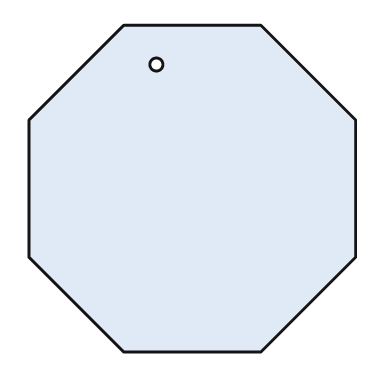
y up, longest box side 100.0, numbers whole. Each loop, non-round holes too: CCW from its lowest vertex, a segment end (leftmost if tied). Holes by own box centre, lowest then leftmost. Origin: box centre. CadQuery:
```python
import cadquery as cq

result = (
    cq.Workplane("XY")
    .moveTo(-21.0, -50.0)
    .lineTo(21.0, -50.0)
    .lineTo(50.0, -21.0)
    .lineTo(50.0, 21.0)
    .lineTo(21.0, 50.0)
    .lineTo(-21.0, 50.0)
    .lineTo(-50.0, 21.0)
    .lineTo(-50.0, -21.0)
    .close()
    .moveTo(-11.0, 38.0)
    .circle(2.0)
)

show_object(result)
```